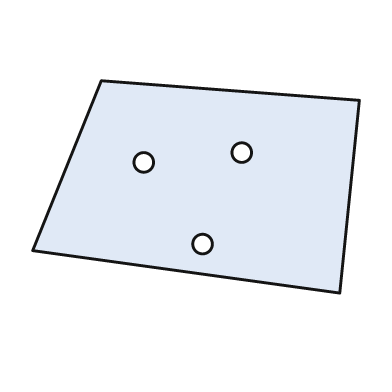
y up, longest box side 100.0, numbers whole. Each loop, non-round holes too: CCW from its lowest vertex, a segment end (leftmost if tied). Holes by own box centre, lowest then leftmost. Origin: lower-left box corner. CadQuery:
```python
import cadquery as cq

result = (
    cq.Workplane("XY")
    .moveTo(94.0, 0.0)
    .lineTo(100.0, 59.0)
    .lineTo(21.0, 65.0)
    .lineTo(0.0, 13.0)
    .close()
    .moveTo(52.0, 15.0)
    .circle(3.0)
    .moveTo(34.0, 40.0)
    .circle(3.0)
    .moveTo(64.0, 43.0)
    .circle(3.0)
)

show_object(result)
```